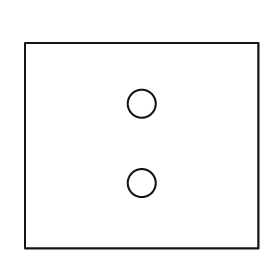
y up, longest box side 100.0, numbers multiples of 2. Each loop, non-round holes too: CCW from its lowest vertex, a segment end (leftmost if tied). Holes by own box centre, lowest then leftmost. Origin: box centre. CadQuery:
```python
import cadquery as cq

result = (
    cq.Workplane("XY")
    .moveTo(-50.0, -44.0)
    .lineTo(50.0, -44.0)
    .lineTo(50.0, 44.0)
    .lineTo(-50.0, 44.0)
    .close()
    .moveTo(0.0, -16.0)
    .circle(6.0)
    .moveTo(0.0, 18.0)
    .circle(6.0)
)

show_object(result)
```